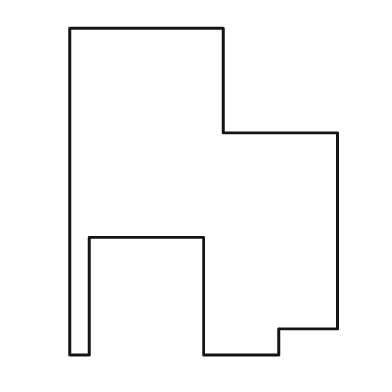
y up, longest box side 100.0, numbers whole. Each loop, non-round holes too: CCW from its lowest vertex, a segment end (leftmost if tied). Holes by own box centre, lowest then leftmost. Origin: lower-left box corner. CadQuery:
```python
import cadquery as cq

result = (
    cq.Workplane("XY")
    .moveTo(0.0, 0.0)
    .lineTo(6.0, 0.0)
    .lineTo(6.0, 36.0)
    .lineTo(41.0, 36.0)
    .lineTo(41.0, 0.0)
    .lineTo(64.0, 0.0)
    .lineTo(64.0, 8.0)
    .lineTo(82.0, 8.0)
    .lineTo(82.0, 68.0)
    .lineTo(47.0, 68.0)
    .lineTo(47.0, 100.0)
    .lineTo(0.0, 100.0)
    .close()
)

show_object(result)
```